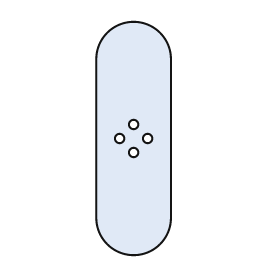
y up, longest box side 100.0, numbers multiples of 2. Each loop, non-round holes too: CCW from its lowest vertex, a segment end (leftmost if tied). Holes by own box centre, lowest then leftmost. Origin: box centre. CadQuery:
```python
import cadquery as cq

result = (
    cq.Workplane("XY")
    .moveTo(-16.0, -34.0)
    .threePointArc((0.0, -50.0), (16.0, -34.0))
    .lineTo(16.0, 34.0)
    .threePointArc((0.0, 50.0), (-16.0, 34.0))
    .close()
    .moveTo(0.0, -6.0)
    .circle(2.0)
    .moveTo(-6.0, 0.0)
    .circle(2.0)
    .moveTo(6.0, 0.0)
    .circle(2.0)
    .moveTo(0.0, 6.0)
    .circle(2.0)
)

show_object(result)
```